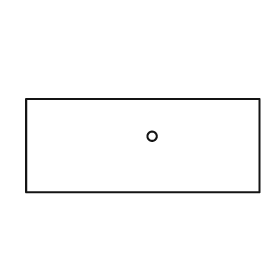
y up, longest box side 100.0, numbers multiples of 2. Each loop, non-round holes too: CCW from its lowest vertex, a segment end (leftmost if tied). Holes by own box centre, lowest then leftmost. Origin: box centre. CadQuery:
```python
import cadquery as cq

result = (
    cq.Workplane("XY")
    .moveTo(-50.0, -20.0)
    .lineTo(50.0, -20.0)
    .lineTo(50.0, 20.0)
    .lineTo(-50.0, 20.0)
    .close()
    .moveTo(4.0, 4.0)
    .circle(2.0)
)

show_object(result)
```